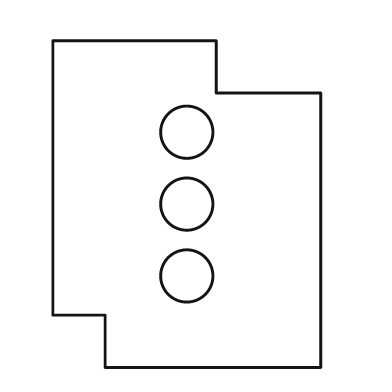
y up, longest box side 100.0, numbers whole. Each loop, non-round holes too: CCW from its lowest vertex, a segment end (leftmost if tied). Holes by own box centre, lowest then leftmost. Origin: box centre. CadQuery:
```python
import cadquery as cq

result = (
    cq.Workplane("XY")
    .moveTo(-25.0, -50.0)
    .lineTo(41.0, -50.0)
    .lineTo(41.0, 34.0)
    .lineTo(9.0, 34.0)
    .lineTo(9.0, 50.0)
    .lineTo(-41.0, 50.0)
    .lineTo(-41.0, -34.0)
    .lineTo(-25.0, -34.0)
    .close()
    .moveTo(0.0, -22.0)
    .circle(8.0)
    .moveTo(0.0, 0.0)
    .circle(8.0)
    .moveTo(0.0, 22.0)
    .circle(8.0)
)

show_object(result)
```